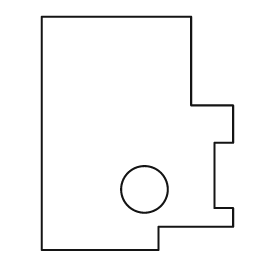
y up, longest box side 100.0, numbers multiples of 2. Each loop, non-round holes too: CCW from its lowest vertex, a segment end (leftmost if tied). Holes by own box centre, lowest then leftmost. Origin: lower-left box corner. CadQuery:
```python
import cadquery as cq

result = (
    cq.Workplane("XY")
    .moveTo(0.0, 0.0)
    .lineTo(50.0, 0.0)
    .lineTo(50.0, 10.0)
    .lineTo(82.0, 10.0)
    .lineTo(82.0, 18.0)
    .lineTo(74.0, 18.0)
    .lineTo(74.0, 46.0)
    .lineTo(82.0, 46.0)
    .lineTo(82.0, 62.0)
    .lineTo(64.0, 62.0)
    .lineTo(64.0, 100.0)
    .lineTo(0.0, 100.0)
    .close()
    .moveTo(44.0, 26.0)
    .circle(10.0)
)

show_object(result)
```